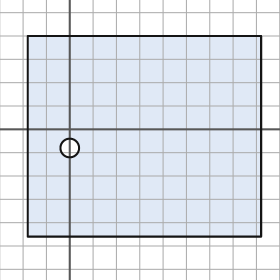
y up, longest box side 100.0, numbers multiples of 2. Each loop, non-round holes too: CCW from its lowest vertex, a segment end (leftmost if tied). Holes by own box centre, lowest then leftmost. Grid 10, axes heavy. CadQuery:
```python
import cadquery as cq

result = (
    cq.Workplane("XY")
    .moveTo(-18.0, -46.0)
    .lineTo(82.0, -46.0)
    .lineTo(82.0, 40.0)
    .lineTo(-18.0, 40.0)
    .close()
    .moveTo(0.0, -8.0)
    .circle(4.0)
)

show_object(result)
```